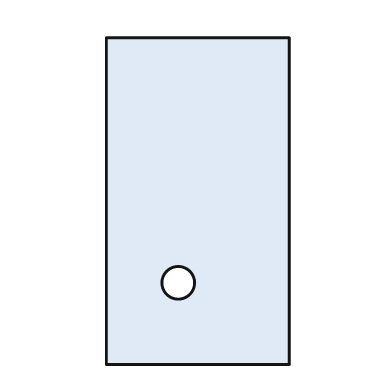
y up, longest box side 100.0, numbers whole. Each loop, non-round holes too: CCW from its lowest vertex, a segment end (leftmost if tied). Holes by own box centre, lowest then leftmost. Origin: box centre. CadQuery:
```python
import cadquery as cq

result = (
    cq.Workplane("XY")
    .moveTo(-28.0, -50.0)
    .lineTo(28.0, -50.0)
    .lineTo(28.0, 50.0)
    .lineTo(-28.0, 50.0)
    .close()
    .moveTo(-6.0, -25.0)
    .circle(5.0)
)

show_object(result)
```